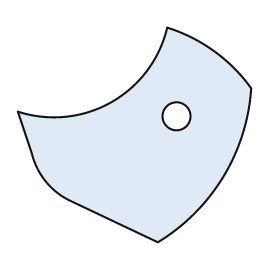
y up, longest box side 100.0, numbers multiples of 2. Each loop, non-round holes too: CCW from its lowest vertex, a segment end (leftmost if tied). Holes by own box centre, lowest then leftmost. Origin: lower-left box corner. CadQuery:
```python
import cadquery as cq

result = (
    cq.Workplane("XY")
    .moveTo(60.0, 0.0)
    .threePointArc((88.0, 28.0), (100.0, 66.0))
    .threePointArc((84.0, 82.0), (64.0, 92.0))
    .threePointArc((40.0, 60.0), (0.0, 56.0))
    .lineTo(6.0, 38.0)
    .threePointArc((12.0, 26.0), (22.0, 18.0))
    .close()
    .moveTo(68.0, 54.0)
    .circle(6.0)
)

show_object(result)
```